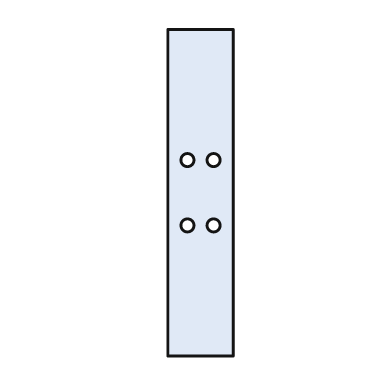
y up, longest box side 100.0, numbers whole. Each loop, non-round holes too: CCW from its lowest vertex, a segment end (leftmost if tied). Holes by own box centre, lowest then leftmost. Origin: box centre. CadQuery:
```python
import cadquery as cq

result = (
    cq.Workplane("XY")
    .moveTo(-10.0, -50.0)
    .lineTo(10.0, -50.0)
    .lineTo(10.0, 50.0)
    .lineTo(-10.0, 50.0)
    .close()
    .moveTo(-4.0, -10.0)
    .circle(2.0)
    .moveTo(4.0, -10.0)
    .circle(2.0)
    .moveTo(-4.0, 10.0)
    .circle(2.0)
    .moveTo(4.0, 10.0)
    .circle(2.0)
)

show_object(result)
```